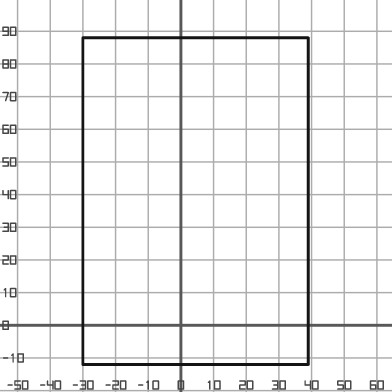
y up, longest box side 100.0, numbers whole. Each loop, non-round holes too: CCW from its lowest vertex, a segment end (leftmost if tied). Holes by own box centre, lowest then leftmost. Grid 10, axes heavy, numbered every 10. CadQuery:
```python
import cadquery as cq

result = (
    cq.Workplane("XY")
    .moveTo(-30.0, -12.0)
    .lineTo(39.0, -12.0)
    .lineTo(39.0, 88.0)
    .lineTo(-30.0, 88.0)
    .close()
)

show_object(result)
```